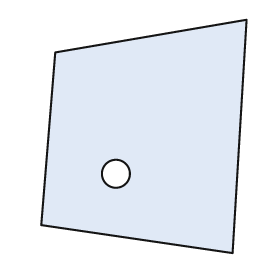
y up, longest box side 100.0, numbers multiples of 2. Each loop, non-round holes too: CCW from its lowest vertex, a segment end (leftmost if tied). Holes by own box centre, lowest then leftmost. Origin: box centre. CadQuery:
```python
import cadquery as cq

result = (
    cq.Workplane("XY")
    .moveTo(38.0, -50.0)
    .lineTo(44.0, 50.0)
    .lineTo(-38.0, 36.0)
    .lineTo(-44.0, -38.0)
    .close()
    .moveTo(-12.0, -16.0)
    .circle(6.0)
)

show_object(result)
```